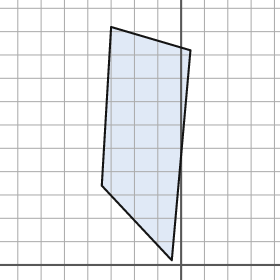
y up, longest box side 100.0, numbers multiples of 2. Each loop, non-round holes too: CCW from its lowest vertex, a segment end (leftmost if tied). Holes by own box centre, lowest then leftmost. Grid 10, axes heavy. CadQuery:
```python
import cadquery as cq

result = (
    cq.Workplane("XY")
    .moveTo(-4.0, 2.0)
    .lineTo(4.0, 92.0)
    .lineTo(-30.0, 102.0)
    .lineTo(-34.0, 34.0)
    .close()
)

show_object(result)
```